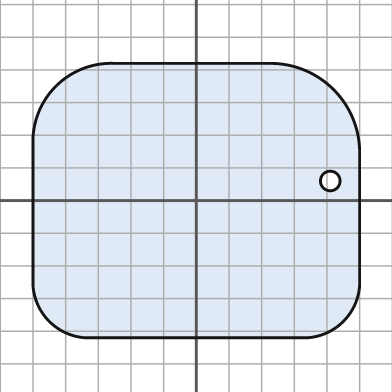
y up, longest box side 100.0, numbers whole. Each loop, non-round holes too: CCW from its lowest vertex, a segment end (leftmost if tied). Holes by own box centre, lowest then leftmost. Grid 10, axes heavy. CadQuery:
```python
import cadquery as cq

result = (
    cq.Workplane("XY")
    .moveTo(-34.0, -42.0)
    .lineTo(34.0, -42.0)
    .threePointArc((45.0, -37.0), (50.0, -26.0))
    .lineTo(50.0, 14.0)
    .threePointArc((42.0, 34.0), (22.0, 42.0))
    .lineTo(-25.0, 42.0)
    .threePointArc((-43.0, 35.0), (-50.0, 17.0))
    .lineTo(-50.0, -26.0)
    .threePointArc((-45.0, -37.0), (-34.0, -42.0))
    .close()
    .moveTo(41.0, 6.0)
    .circle(3.0)
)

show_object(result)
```